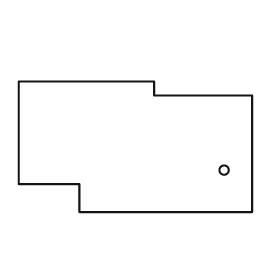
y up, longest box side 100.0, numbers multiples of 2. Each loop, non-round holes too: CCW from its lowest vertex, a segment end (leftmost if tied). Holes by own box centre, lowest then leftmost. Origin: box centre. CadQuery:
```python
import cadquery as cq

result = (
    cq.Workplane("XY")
    .moveTo(-24.0, -28.0)
    .lineTo(50.0, -28.0)
    .lineTo(50.0, 22.0)
    .lineTo(8.0, 22.0)
    .lineTo(8.0, 28.0)
    .lineTo(-50.0, 28.0)
    .lineTo(-50.0, -16.0)
    .lineTo(-24.0, -16.0)
    .close()
    .moveTo(38.0, -10.0)
    .circle(2.0)
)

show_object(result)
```